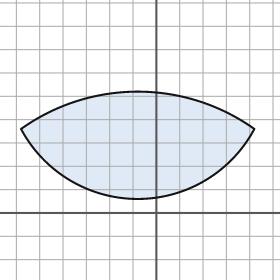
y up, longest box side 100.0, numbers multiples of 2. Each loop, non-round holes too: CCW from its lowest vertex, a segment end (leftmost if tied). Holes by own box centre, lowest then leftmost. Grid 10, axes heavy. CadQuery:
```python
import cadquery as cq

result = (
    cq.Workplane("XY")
    .moveTo(-58.0, 36.0)
    .threePointArc((-8.0, 6.0), (42.0, 36.0))
    .threePointArc((-8.0, 52.0), (-58.0, 36.0))
    .close()
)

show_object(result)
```